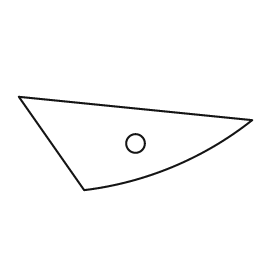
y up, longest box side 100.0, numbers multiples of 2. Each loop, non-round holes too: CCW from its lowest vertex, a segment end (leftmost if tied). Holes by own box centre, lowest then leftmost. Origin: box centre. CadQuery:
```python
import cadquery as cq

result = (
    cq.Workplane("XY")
    .moveTo(-22.0, -20.0)
    .threePointArc((16.0, -10.0), (50.0, 10.0))
    .lineTo(-50.0, 20.0)
    .close()
    .moveTo(0.0, 0.0)
    .circle(4.0)
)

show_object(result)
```